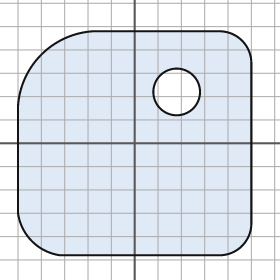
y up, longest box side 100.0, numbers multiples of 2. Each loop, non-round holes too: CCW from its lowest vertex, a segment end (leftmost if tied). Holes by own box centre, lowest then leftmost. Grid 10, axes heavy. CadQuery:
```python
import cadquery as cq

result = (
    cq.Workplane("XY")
    .moveTo(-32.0, -48.0)
    .lineTo(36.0, -48.0)
    .threePointArc((46.0, -44.0), (50.0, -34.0))
    .lineTo(50.0, 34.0)
    .threePointArc((46.0, 44.0), (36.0, 48.0))
    .lineTo(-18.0, 48.0)
    .threePointArc((-40.0, 38.0), (-50.0, 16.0))
    .lineTo(-50.0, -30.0)
    .threePointArc((-44.0, -42.0), (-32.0, -48.0))
    .close()
    .moveTo(18.0, 22.0)
    .circle(10.0)
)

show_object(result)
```